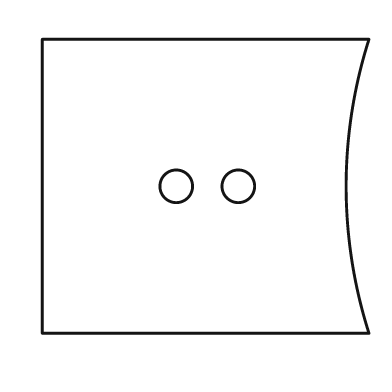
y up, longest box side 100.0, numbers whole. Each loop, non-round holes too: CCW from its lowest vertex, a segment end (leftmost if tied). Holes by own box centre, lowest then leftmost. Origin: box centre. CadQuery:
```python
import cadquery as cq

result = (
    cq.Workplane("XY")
    .moveTo(-50.0, -45.0)
    .lineTo(50.0, -45.0)
    .threePointArc((43.0, 0.0), (50.0, 45.0))
    .lineTo(-50.0, 45.0)
    .close()
    .moveTo(-9.0, 0.0)
    .circle(5.0)
    .moveTo(10.0, 0.0)
    .circle(5.0)
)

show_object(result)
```